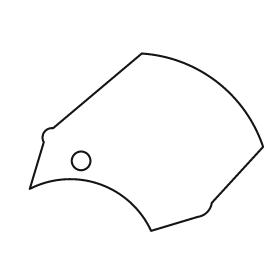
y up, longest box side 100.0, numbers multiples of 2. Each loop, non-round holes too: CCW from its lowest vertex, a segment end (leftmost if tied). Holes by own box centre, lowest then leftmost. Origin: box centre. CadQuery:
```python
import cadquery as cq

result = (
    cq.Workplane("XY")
    .moveTo(2.0, -38.0)
    .lineTo(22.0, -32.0)
    .threePointArc((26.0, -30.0), (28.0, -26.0))
    .lineTo(50.0, -2.0)
    .threePointArc((30.0, 26.0), (-2.0, 38.0))
    .lineTo(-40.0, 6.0)
    .threePointArc((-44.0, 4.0), (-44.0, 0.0))
    .lineTo(-50.0, -20.0)
    .threePointArc((-20.0, -18.0), (2.0, -38.0))
    .close()
    .moveTo(-28.0, -8.0)
    .circle(4.0)
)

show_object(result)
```